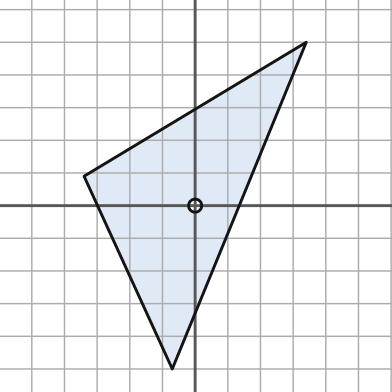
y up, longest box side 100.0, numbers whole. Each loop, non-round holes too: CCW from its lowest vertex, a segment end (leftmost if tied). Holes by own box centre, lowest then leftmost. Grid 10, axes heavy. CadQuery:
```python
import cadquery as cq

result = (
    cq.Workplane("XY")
    .moveTo(-7.0, -50.0)
    .lineTo(34.0, 50.0)
    .lineTo(-34.0, 9.0)
    .close()
    .moveTo(0.0, 0.0)
    .circle(2.0)
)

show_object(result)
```